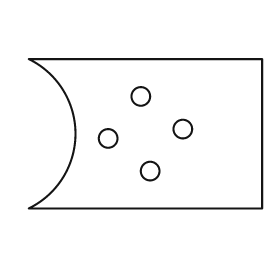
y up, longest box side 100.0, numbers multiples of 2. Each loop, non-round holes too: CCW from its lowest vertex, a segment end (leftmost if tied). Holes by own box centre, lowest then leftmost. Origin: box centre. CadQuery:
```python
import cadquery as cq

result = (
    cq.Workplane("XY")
    .moveTo(-50.0, -32.0)
    .lineTo(50.0, -32.0)
    .lineTo(50.0, 32.0)
    .lineTo(-50.0, 32.0)
    .threePointArc((-30.0, 0.0), (-50.0, -32.0))
    .close()
    .moveTo(2.0, -16.0)
    .circle(4.0)
    .moveTo(-16.0, -2.0)
    .circle(4.0)
    .moveTo(16.0, 2.0)
    .circle(4.0)
    .moveTo(-2.0, 16.0)
    .circle(4.0)
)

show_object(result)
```